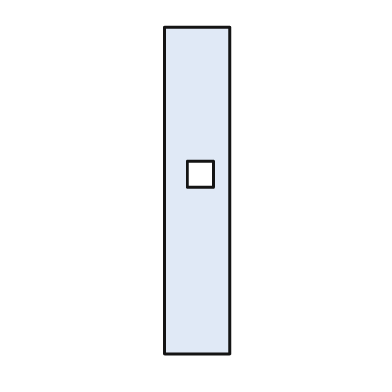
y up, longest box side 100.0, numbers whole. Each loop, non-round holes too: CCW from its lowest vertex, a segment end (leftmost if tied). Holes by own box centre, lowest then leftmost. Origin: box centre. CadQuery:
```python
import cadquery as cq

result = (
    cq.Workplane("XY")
    .moveTo(-10.0, -50.0)
    .lineTo(10.0, -50.0)
    .lineTo(10.0, 50.0)
    .lineTo(-10.0, 50.0)
    .close()
    .moveTo(-3.0, 1.0)
    .lineTo(5.0, 1.0)
    .lineTo(5.0, 9.0)
    .lineTo(-3.0, 9.0)
    .close()
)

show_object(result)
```